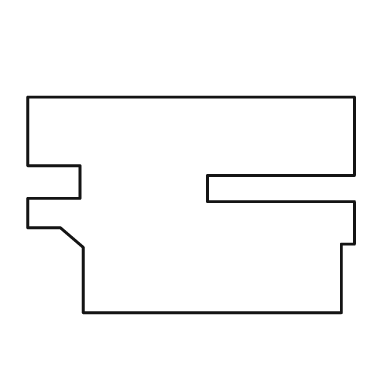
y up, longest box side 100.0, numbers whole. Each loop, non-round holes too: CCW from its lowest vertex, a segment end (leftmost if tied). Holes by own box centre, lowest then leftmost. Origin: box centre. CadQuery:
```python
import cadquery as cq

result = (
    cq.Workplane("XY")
    .moveTo(-33.0, -33.0)
    .lineTo(46.0, -33.0)
    .lineTo(46.0, -12.0)
    .lineTo(50.0, -12.0)
    .lineTo(50.0, 1.0)
    .lineTo(5.0, 1.0)
    .lineTo(5.0, 9.0)
    .lineTo(50.0, 9.0)
    .lineTo(50.0, 33.0)
    .lineTo(-50.0, 33.0)
    .lineTo(-50.0, 12.0)
    .lineTo(-34.0, 12.0)
    .lineTo(-34.0, 2.0)
    .lineTo(-50.0, 2.0)
    .lineTo(-50.0, -7.0)
    .lineTo(-40.0, -7.0)
    .lineTo(-33.0, -13.0)
    .close()
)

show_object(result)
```